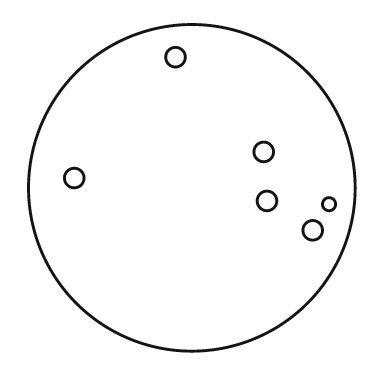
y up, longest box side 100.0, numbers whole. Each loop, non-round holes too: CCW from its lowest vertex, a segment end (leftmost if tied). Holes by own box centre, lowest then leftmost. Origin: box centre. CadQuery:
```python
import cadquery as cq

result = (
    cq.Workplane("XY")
    .moveTo(0.0, 0.0)
    .circle(50.0)
    .moveTo(37.0, -13.0)
    .circle(3.0)
    .moveTo(42.0, -5.0)
    .circle(2.0)
    .moveTo(23.0, -4.0)
    .circle(3.0)
    .moveTo(-36.0, 3.0)
    .circle(3.0)
    .moveTo(22.0, 11.0)
    .circle(3.0)
    .moveTo(-5.0, 40.0)
    .circle(3.0)
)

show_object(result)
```